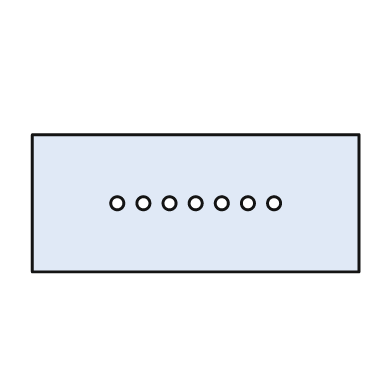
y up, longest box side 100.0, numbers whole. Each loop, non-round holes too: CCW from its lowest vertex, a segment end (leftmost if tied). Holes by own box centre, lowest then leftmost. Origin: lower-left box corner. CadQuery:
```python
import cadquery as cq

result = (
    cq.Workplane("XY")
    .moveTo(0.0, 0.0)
    .lineTo(100.0, 0.0)
    .lineTo(100.0, 42.0)
    .lineTo(0.0, 42.0)
    .close()
    .moveTo(26.0, 21.0)
    .circle(2.0)
    .moveTo(34.0, 21.0)
    .circle(2.0)
    .moveTo(42.0, 21.0)
    .circle(2.0)
    .moveTo(50.0, 21.0)
    .circle(2.0)
    .moveTo(58.0, 21.0)
    .circle(2.0)
    .moveTo(66.0, 21.0)
    .circle(2.0)
    .moveTo(74.0, 21.0)
    .circle(2.0)
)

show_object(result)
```